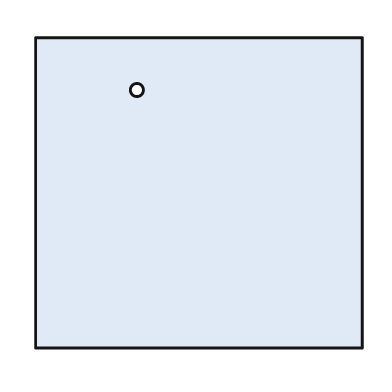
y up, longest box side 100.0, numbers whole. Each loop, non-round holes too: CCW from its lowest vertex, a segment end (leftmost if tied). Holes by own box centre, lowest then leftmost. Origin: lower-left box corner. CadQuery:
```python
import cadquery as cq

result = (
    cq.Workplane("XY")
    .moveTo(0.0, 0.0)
    .lineTo(100.0, 0.0)
    .lineTo(100.0, 95.0)
    .lineTo(0.0, 95.0)
    .close()
    .moveTo(31.0, 79.0)
    .circle(2.0)
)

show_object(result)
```